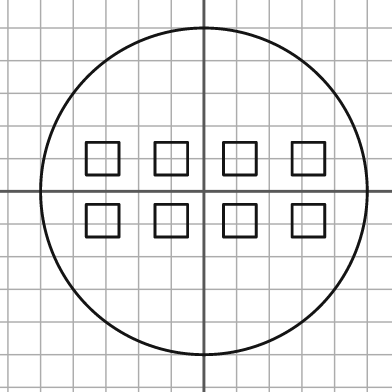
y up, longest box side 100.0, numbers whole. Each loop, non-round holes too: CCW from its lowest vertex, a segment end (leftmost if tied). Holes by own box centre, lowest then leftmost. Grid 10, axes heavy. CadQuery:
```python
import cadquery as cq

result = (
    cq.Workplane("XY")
    .moveTo(0.0, 0.0)
    .circle(50.0)
    .moveTo(-36.0, -14.0)
    .lineTo(-26.0, -14.0)
    .lineTo(-26.0, -4.0)
    .lineTo(-36.0, -4.0)
    .close()
    .moveTo(-15.0, -14.0)
    .lineTo(-5.0, -14.0)
    .lineTo(-5.0, -4.0)
    .lineTo(-15.0, -4.0)
    .close()
    .moveTo(6.0, -14.0)
    .lineTo(16.0, -14.0)
    .lineTo(16.0, -4.0)
    .lineTo(6.0, -4.0)
    .close()
    .moveTo(27.0, -14.0)
    .lineTo(37.0, -14.0)
    .lineTo(37.0, -4.0)
    .lineTo(27.0, -4.0)
    .close()
    .moveTo(-36.0, 5.0)
    .lineTo(-26.0, 5.0)
    .lineTo(-26.0, 15.0)
    .lineTo(-36.0, 15.0)
    .close()
    .moveTo(-15.0, 5.0)
    .lineTo(-5.0, 5.0)
    .lineTo(-5.0, 15.0)
    .lineTo(-15.0, 15.0)
    .close()
    .moveTo(6.0, 5.0)
    .lineTo(16.0, 5.0)
    .lineTo(16.0, 15.0)
    .lineTo(6.0, 15.0)
    .close()
    .moveTo(27.0, 5.0)
    .lineTo(37.0, 5.0)
    .lineTo(37.0, 15.0)
    .lineTo(27.0, 15.0)
    .close()
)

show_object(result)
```